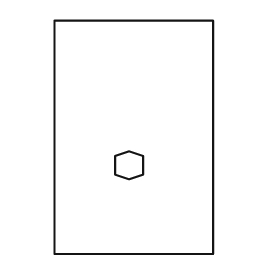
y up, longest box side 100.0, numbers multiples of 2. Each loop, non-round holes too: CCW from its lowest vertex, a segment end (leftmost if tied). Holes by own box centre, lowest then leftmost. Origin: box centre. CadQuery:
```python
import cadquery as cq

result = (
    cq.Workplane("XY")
    .moveTo(-34.0, -50.0)
    .lineTo(34.0, -50.0)
    .lineTo(34.0, 50.0)
    .lineTo(-34.0, 50.0)
    .close()
    .moveTo(-2.0, -18.0)
    .lineTo(4.0, -16.0)
    .lineTo(4.0, -8.0)
    .lineTo(-2.0, -6.0)
    .lineTo(-8.0, -8.0)
    .lineTo(-8.0, -16.0)
    .close()
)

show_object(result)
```